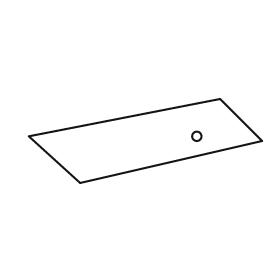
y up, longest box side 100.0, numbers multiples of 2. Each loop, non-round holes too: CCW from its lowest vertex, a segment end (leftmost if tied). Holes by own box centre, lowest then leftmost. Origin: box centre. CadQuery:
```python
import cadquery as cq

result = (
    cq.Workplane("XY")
    .moveTo(-28.0, -18.0)
    .lineTo(50.0, 0.0)
    .lineTo(32.0, 18.0)
    .lineTo(-50.0, 2.0)
    .close()
    .moveTo(22.0, 2.0)
    .circle(2.0)
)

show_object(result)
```